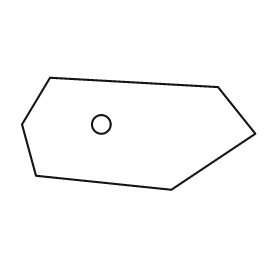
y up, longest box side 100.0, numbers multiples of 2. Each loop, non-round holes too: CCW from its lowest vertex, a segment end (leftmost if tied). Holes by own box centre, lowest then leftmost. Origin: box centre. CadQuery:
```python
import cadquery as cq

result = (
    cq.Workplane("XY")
    .moveTo(14.0, -24.0)
    .lineTo(50.0, 0.0)
    .lineTo(34.0, 20.0)
    .lineTo(-38.0, 24.0)
    .lineTo(-50.0, 4.0)
    .lineTo(-44.0, -18.0)
    .close()
    .moveTo(-16.0, 4.0)
    .circle(4.0)
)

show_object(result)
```